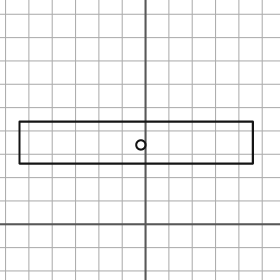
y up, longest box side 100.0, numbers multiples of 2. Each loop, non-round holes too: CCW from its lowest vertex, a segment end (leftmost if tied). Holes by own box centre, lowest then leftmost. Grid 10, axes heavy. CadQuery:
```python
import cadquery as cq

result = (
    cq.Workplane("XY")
    .moveTo(-54.0, 26.0)
    .lineTo(46.0, 26.0)
    .lineTo(46.0, 44.0)
    .lineTo(-54.0, 44.0)
    .close()
    .moveTo(-2.0, 34.0)
    .circle(2.0)
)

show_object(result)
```